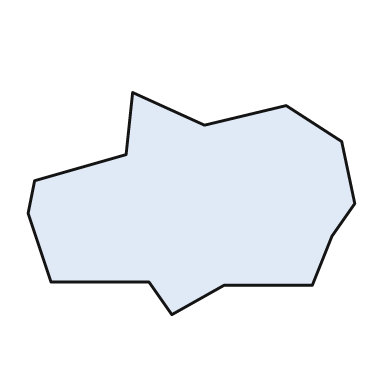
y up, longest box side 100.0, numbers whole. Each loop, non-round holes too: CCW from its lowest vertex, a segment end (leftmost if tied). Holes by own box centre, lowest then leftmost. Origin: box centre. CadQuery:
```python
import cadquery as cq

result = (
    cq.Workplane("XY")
    .moveTo(-6.0, -34.0)
    .lineTo(10.0, -25.0)
    .lineTo(37.0, -25.0)
    .lineTo(43.0, -10.0)
    .lineTo(50.0, 0.0)
    .lineTo(46.0, 19.0)
    .lineTo(29.0, 30.0)
    .lineTo(4.0, 24.0)
    .lineTo(-18.0, 34.0)
    .lineTo(-20.0, 15.0)
    .lineTo(-48.0, 7.0)
    .lineTo(-50.0, -3.0)
    .lineTo(-43.0, -24.0)
    .lineTo(-13.0, -24.0)
    .close()
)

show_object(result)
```